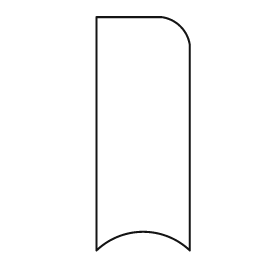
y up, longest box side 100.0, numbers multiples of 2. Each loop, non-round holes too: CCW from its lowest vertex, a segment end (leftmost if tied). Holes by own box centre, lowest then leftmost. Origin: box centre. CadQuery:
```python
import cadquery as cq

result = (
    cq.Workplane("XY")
    .moveTo(-20.0, -50.0)
    .threePointArc((0.0, -42.0), (20.0, -50.0))
    .lineTo(20.0, 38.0)
    .threePointArc((16.0, 46.0), (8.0, 50.0))
    .lineTo(-20.0, 50.0)
    .close()
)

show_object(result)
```